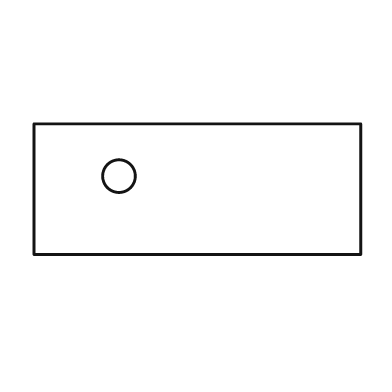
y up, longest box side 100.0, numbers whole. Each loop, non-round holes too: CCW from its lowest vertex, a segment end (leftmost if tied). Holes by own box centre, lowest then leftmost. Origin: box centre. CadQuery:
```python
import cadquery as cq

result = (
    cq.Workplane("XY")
    .moveTo(-50.0, -20.0)
    .lineTo(50.0, -20.0)
    .lineTo(50.0, 20.0)
    .lineTo(-50.0, 20.0)
    .close()
    .moveTo(-24.0, 4.0)
    .circle(5.0)
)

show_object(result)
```